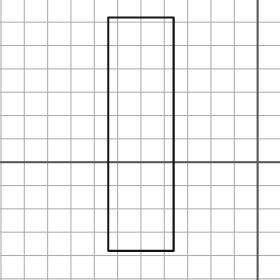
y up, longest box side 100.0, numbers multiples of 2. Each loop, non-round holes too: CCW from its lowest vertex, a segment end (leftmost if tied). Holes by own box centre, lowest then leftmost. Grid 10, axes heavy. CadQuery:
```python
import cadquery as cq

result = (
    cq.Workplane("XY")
    .moveTo(-64.0, -38.0)
    .lineTo(-36.0, -38.0)
    .lineTo(-36.0, 62.0)
    .lineTo(-64.0, 62.0)
    .close()
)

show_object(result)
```